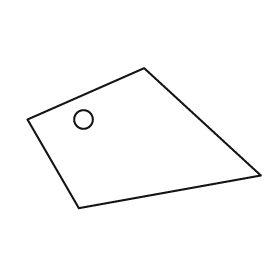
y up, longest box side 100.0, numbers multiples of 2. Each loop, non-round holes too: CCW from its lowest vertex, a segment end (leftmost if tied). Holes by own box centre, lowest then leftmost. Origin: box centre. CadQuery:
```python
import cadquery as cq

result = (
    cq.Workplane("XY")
    .moveTo(-28.0, -30.0)
    .lineTo(50.0, -16.0)
    .lineTo(0.0, 30.0)
    .lineTo(-50.0, 8.0)
    .close()
    .moveTo(-26.0, 8.0)
    .circle(4.0)
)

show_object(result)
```